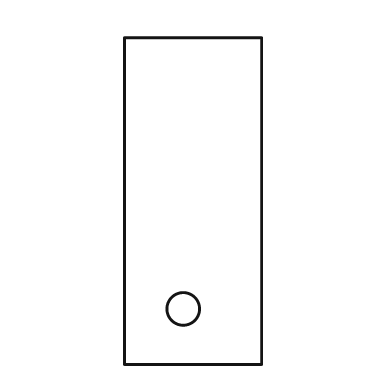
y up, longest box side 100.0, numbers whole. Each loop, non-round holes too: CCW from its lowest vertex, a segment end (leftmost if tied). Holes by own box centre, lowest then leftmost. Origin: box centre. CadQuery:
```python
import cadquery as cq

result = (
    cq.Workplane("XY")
    .moveTo(-21.0, -50.0)
    .lineTo(21.0, -50.0)
    .lineTo(21.0, 50.0)
    .lineTo(-21.0, 50.0)
    .close()
    .moveTo(-3.0, -33.0)
    .circle(5.0)
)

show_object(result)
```